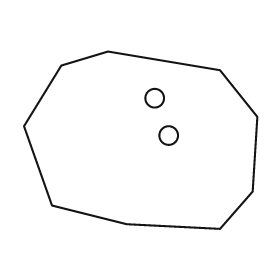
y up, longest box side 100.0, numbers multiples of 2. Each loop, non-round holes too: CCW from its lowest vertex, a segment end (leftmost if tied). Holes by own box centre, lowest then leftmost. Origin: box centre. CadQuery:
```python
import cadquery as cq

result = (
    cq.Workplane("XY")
    .moveTo(34.0, -38.0)
    .lineTo(48.0, -22.0)
    .lineTo(50.0, 10.0)
    .lineTo(34.0, 30.0)
    .lineTo(-14.0, 38.0)
    .lineTo(-34.0, 32.0)
    .lineTo(-50.0, 6.0)
    .lineTo(-38.0, -28.0)
    .lineTo(-6.0, -36.0)
    .close()
    .moveTo(12.0, 2.0)
    .circle(4.0)
    .moveTo(6.0, 18.0)
    .circle(4.0)
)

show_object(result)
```